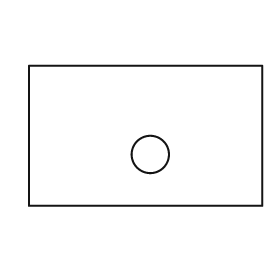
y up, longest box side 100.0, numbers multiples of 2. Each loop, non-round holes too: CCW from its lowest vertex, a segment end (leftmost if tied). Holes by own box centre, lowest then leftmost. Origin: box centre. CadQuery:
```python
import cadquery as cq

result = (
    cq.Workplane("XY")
    .moveTo(-50.0, -30.0)
    .lineTo(50.0, -30.0)
    .lineTo(50.0, 30.0)
    .lineTo(-50.0, 30.0)
    .close()
    .moveTo(2.0, -8.0)
    .circle(8.0)
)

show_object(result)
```